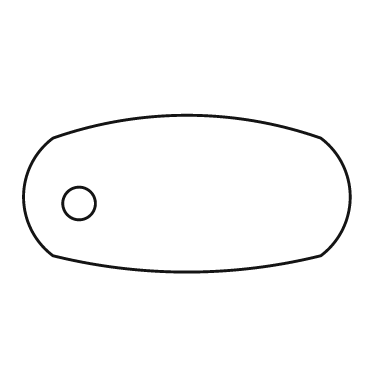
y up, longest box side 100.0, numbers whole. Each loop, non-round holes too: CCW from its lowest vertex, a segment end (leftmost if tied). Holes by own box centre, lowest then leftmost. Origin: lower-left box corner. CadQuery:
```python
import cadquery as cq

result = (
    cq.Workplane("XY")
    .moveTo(9.0, 5.0)
    .threePointArc((50.0, 0.0), (91.0, 5.0))
    .threePointArc((100.0, 23.0), (91.0, 41.0))
    .threePointArc((50.0, 48.0), (9.0, 41.0))
    .threePointArc((0.0, 23.0), (9.0, 5.0))
    .close()
    .moveTo(17.0, 21.0)
    .circle(5.0)
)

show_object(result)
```